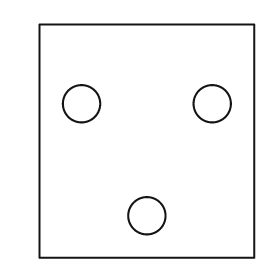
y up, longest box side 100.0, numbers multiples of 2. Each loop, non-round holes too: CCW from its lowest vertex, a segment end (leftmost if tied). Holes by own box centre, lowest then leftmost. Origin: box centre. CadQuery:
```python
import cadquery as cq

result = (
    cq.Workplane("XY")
    .moveTo(-46.0, -50.0)
    .lineTo(46.0, -50.0)
    .lineTo(46.0, 50.0)
    .lineTo(-46.0, 50.0)
    .close()
    .moveTo(0.0, -32.0)
    .circle(8.0)
    .moveTo(-28.0, 16.0)
    .circle(8.0)
    .moveTo(28.0, 16.0)
    .circle(8.0)
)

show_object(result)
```